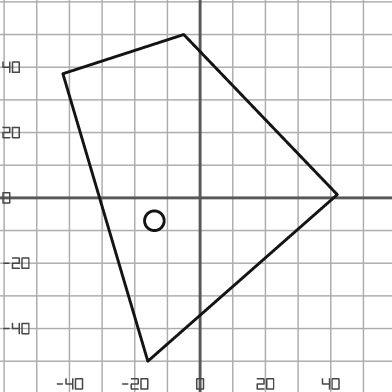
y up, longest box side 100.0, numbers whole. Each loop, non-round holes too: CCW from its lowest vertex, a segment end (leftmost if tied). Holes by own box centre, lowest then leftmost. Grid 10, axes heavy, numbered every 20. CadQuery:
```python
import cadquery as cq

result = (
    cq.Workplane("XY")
    .moveTo(-16.0, -50.0)
    .lineTo(42.0, 1.0)
    .lineTo(-5.0, 50.0)
    .lineTo(-42.0, 38.0)
    .close()
    .moveTo(-14.0, -7.0)
    .circle(3.0)
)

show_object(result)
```